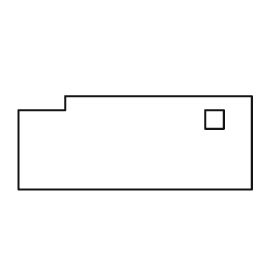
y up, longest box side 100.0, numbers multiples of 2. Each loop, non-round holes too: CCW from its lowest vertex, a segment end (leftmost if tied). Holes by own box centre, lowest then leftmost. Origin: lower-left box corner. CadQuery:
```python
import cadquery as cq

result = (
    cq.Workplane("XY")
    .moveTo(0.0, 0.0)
    .lineTo(100.0, 0.0)
    .lineTo(100.0, 40.0)
    .lineTo(20.0, 40.0)
    .lineTo(20.0, 34.0)
    .lineTo(0.0, 34.0)
    .close()
    .moveTo(80.0, 26.0)
    .lineTo(88.0, 26.0)
    .lineTo(88.0, 34.0)
    .lineTo(80.0, 34.0)
    .close()
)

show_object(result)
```